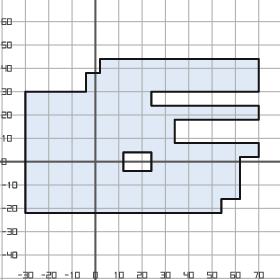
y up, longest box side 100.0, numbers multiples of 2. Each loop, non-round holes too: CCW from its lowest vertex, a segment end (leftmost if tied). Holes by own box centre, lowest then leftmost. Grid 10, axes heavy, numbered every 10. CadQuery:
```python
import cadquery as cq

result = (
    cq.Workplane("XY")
    .moveTo(-30.0, -22.0)
    .lineTo(54.0, -22.0)
    .lineTo(54.0, -16.0)
    .lineTo(62.0, -16.0)
    .lineTo(62.0, 2.0)
    .lineTo(70.0, 2.0)
    .lineTo(70.0, 8.0)
    .lineTo(34.0, 8.0)
    .lineTo(34.0, 18.0)
    .lineTo(70.0, 18.0)
    .lineTo(70.0, 24.0)
    .lineTo(24.0, 24.0)
    .lineTo(24.0, 30.0)
    .lineTo(70.0, 30.0)
    .lineTo(70.0, 44.0)
    .lineTo(2.0, 44.0)
    .lineTo(2.0, 38.0)
    .lineTo(-4.0, 38.0)
    .lineTo(-4.0, 30.0)
    .lineTo(-30.0, 30.0)
    .close()
    .moveTo(12.0, -4.0)
    .lineTo(24.0, -4.0)
    .lineTo(24.0, 4.0)
    .lineTo(12.0, 4.0)
    .close()
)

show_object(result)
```